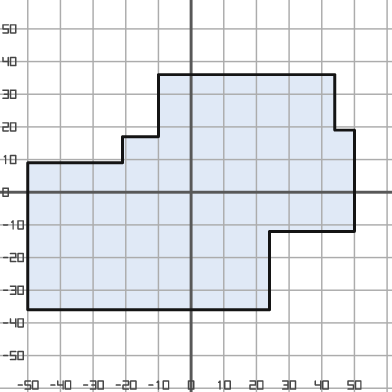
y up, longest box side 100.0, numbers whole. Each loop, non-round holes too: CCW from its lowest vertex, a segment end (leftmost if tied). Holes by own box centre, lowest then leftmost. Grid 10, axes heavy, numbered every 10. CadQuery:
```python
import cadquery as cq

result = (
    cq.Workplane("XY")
    .moveTo(-50.0, -36.0)
    .lineTo(24.0, -36.0)
    .lineTo(24.0, -12.0)
    .lineTo(50.0, -12.0)
    .lineTo(50.0, 19.0)
    .lineTo(44.0, 19.0)
    .lineTo(44.0, 36.0)
    .lineTo(-10.0, 36.0)
    .lineTo(-10.0, 17.0)
    .lineTo(-21.0, 17.0)
    .lineTo(-21.0, 9.0)
    .lineTo(-50.0, 9.0)
    .close()
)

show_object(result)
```